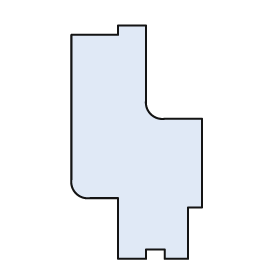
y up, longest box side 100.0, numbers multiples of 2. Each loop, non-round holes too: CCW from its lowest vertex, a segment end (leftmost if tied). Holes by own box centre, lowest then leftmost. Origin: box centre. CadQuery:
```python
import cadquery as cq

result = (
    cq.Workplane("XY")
    .moveTo(-8.0, -50.0)
    .lineTo(4.0, -50.0)
    .lineTo(4.0, -46.0)
    .lineTo(12.0, -46.0)
    .lineTo(12.0, -50.0)
    .lineTo(22.0, -50.0)
    .lineTo(22.0, -28.0)
    .lineTo(28.0, -28.0)
    .lineTo(28.0, 10.0)
    .lineTo(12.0, 10.0)
    .threePointArc((6.0, 12.0), (4.0, 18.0))
    .lineTo(4.0, 50.0)
    .lineTo(-8.0, 50.0)
    .lineTo(-8.0, 46.0)
    .lineTo(-28.0, 46.0)
    .lineTo(-28.0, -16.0)
    .threePointArc((-26.0, -22.0), (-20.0, -24.0))
    .lineTo(-8.0, -24.0)
    .close()
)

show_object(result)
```